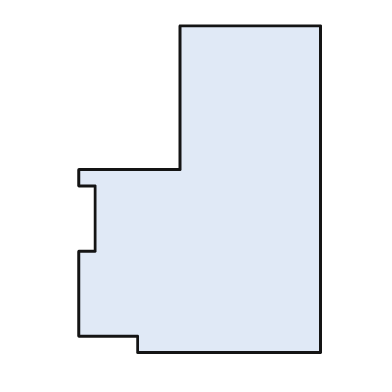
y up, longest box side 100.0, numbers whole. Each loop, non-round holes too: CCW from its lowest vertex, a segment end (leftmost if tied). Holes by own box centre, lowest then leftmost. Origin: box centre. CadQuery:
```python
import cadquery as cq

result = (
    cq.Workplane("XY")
    .moveTo(-19.0, -50.0)
    .lineTo(37.0, -50.0)
    .lineTo(37.0, 50.0)
    .lineTo(-6.0, 50.0)
    .lineTo(-6.0, 6.0)
    .lineTo(-37.0, 6.0)
    .lineTo(-37.0, 1.0)
    .lineTo(-32.0, 1.0)
    .lineTo(-32.0, -19.0)
    .lineTo(-37.0, -19.0)
    .lineTo(-37.0, -45.0)
    .lineTo(-19.0, -45.0)
    .close()
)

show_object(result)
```